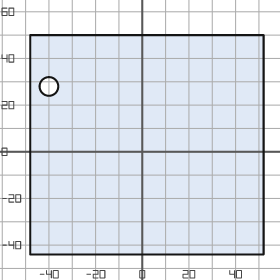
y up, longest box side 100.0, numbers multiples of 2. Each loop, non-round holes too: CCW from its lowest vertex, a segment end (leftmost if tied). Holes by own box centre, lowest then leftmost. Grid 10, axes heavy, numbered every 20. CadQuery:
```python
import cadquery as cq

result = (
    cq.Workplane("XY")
    .moveTo(-48.0, -44.0)
    .lineTo(52.0, -44.0)
    .lineTo(52.0, 50.0)
    .lineTo(-48.0, 50.0)
    .close()
    .moveTo(-40.0, 28.0)
    .circle(4.0)
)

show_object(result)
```